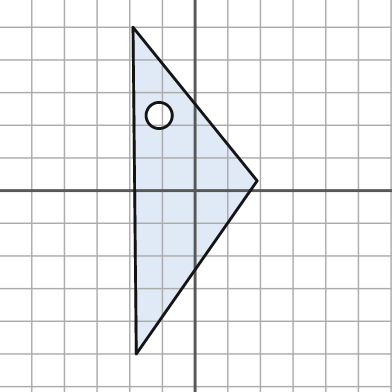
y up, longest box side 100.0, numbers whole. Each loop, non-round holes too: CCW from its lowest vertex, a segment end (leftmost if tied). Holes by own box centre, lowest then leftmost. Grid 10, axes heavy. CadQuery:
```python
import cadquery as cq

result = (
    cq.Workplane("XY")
    .moveTo(-18.0, -50.0)
    .lineTo(19.0, 3.0)
    .lineTo(-19.0, 50.0)
    .close()
    .moveTo(-11.0, 23.0)
    .circle(4.0)
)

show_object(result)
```